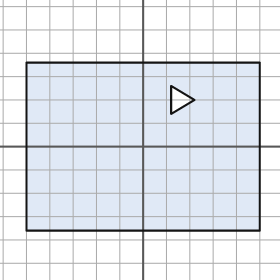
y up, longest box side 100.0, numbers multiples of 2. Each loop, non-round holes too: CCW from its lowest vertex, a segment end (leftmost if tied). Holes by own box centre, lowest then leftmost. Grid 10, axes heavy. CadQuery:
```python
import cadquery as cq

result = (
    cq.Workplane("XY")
    .moveTo(-50.0, -36.0)
    .lineTo(50.0, -36.0)
    .lineTo(50.0, 36.0)
    .lineTo(-50.0, 36.0)
    .close()
    .moveTo(12.0, 14.0)
    .lineTo(22.0, 20.0)
    .lineTo(12.0, 26.0)
    .close()
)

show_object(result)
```